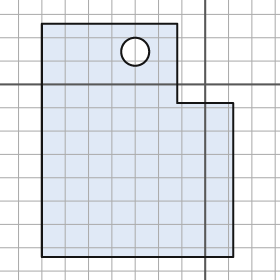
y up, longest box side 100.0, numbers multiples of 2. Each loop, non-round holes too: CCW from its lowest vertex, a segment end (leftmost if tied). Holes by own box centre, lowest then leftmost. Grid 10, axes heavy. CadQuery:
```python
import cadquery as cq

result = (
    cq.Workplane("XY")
    .moveTo(-70.0, -74.0)
    .lineTo(12.0, -74.0)
    .lineTo(12.0, -8.0)
    .lineTo(-12.0, -8.0)
    .lineTo(-12.0, 26.0)
    .lineTo(-70.0, 26.0)
    .close()
    .moveTo(-30.0, 14.0)
    .circle(6.0)
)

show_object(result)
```